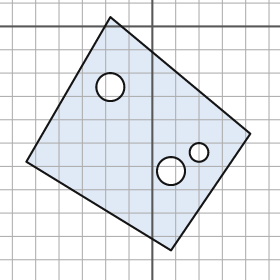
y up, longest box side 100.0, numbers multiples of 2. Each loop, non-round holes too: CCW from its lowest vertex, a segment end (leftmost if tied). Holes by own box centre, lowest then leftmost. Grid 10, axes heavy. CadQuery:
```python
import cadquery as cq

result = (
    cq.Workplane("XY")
    .moveTo(8.0, -96.0)
    .lineTo(42.0, -46.0)
    .lineTo(-18.0, 4.0)
    .lineTo(-54.0, -58.0)
    .close()
    .moveTo(8.0, -62.0)
    .circle(6.0)
    .moveTo(20.0, -54.0)
    .circle(4.0)
    .moveTo(-18.0, -26.0)
    .circle(6.0)
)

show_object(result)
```